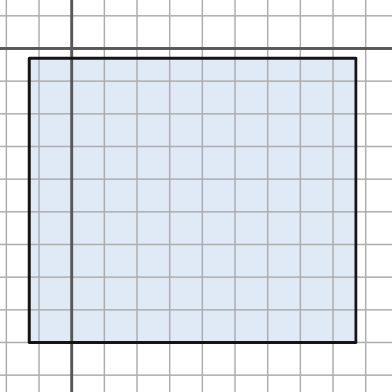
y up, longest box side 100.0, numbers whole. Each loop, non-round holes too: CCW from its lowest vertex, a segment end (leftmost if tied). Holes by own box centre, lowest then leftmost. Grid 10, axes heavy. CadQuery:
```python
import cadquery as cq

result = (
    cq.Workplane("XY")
    .moveTo(-13.0, -90.0)
    .lineTo(87.0, -90.0)
    .lineTo(87.0, -3.0)
    .lineTo(-13.0, -3.0)
    .close()
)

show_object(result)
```